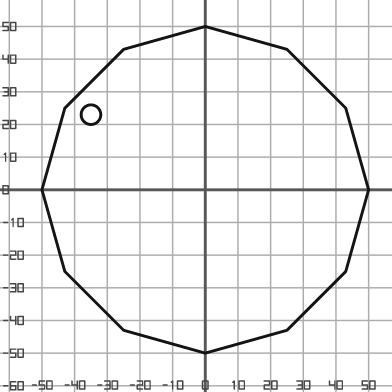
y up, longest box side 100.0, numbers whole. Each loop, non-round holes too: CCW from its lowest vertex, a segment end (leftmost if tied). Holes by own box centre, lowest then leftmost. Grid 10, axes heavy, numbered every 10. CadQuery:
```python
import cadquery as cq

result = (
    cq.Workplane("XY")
    .moveTo(0.0, -50.0)
    .lineTo(25.0, -43.0)
    .lineTo(43.0, -25.0)
    .lineTo(50.0, 0.0)
    .lineTo(43.0, 25.0)
    .lineTo(25.0, 43.0)
    .lineTo(0.0, 50.0)
    .lineTo(-25.0, 43.0)
    .lineTo(-43.0, 25.0)
    .lineTo(-50.0, 0.0)
    .lineTo(-43.0, -25.0)
    .lineTo(-25.0, -43.0)
    .close()
    .moveTo(-35.0, 23.0)
    .circle(3.0)
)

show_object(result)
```